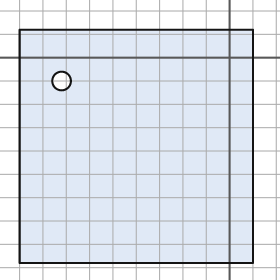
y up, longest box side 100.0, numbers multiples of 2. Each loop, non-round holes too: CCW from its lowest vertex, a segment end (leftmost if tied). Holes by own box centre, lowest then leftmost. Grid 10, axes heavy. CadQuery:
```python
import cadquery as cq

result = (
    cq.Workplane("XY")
    .moveTo(-90.0, -88.0)
    .lineTo(10.0, -88.0)
    .lineTo(10.0, 12.0)
    .lineTo(-90.0, 12.0)
    .close()
    .moveTo(-72.0, -10.0)
    .circle(4.0)
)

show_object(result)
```